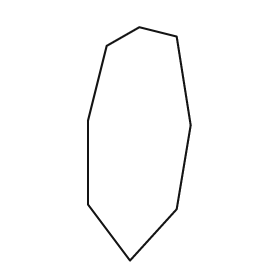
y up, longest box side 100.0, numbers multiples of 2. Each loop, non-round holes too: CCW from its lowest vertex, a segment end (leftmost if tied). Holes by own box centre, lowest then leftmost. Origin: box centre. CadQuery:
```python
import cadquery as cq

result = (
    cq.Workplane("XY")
    .moveTo(-4.0, -50.0)
    .lineTo(16.0, -28.0)
    .lineTo(22.0, 8.0)
    .lineTo(16.0, 46.0)
    .lineTo(0.0, 50.0)
    .lineTo(-14.0, 42.0)
    .lineTo(-22.0, 10.0)
    .lineTo(-22.0, -26.0)
    .close()
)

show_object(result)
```